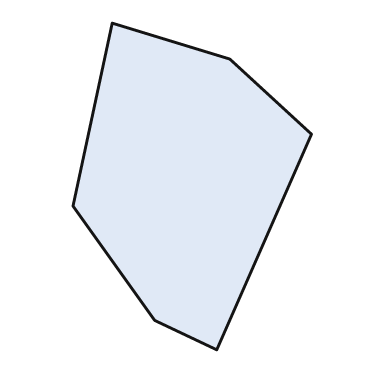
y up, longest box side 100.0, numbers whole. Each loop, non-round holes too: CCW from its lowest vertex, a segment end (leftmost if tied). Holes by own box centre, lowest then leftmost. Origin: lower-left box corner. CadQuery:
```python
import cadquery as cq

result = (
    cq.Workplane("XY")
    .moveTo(44.0, 0.0)
    .lineTo(73.0, 66.0)
    .lineTo(48.0, 89.0)
    .lineTo(12.0, 100.0)
    .lineTo(0.0, 44.0)
    .lineTo(25.0, 9.0)
    .close()
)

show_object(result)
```